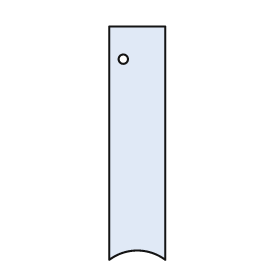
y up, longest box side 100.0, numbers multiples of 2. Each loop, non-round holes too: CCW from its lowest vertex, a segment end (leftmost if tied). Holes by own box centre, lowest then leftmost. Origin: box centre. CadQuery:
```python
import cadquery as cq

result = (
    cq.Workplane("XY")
    .moveTo(-12.0, -50.0)
    .threePointArc((0.0, -46.0), (12.0, -50.0))
    .lineTo(12.0, 50.0)
    .lineTo(-12.0, 50.0)
    .close()
    .moveTo(-6.0, 36.0)
    .circle(2.0)
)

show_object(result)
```